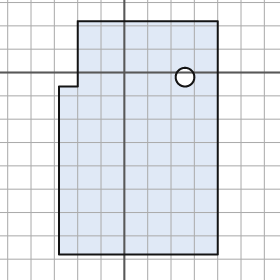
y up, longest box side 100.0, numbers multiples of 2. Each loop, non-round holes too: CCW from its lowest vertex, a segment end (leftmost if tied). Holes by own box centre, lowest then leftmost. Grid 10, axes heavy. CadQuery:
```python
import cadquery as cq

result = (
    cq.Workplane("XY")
    .moveTo(-28.0, -78.0)
    .lineTo(40.0, -78.0)
    .lineTo(40.0, 22.0)
    .lineTo(-20.0, 22.0)
    .lineTo(-20.0, -6.0)
    .lineTo(-28.0, -6.0)
    .close()
    .moveTo(26.0, -2.0)
    .circle(4.0)
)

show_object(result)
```